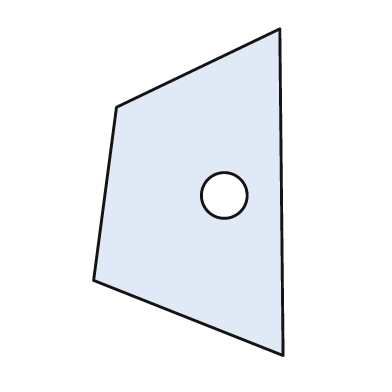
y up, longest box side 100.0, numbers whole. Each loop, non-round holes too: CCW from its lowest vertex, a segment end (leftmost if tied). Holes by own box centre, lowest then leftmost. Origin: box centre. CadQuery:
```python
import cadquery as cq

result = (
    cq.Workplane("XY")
    .moveTo(29.0, -50.0)
    .lineTo(28.0, 50.0)
    .lineTo(-22.0, 26.0)
    .lineTo(-29.0, -27.0)
    .close()
    .moveTo(11.0, -1.0)
    .circle(7.0)
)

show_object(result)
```